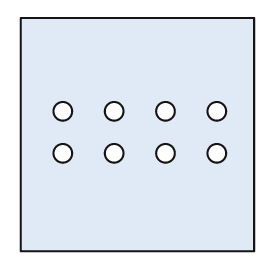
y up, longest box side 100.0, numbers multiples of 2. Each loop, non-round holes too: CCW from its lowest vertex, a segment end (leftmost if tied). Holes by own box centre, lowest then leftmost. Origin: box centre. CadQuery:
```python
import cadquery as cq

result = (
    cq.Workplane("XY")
    .moveTo(-50.0, -50.0)
    .lineTo(50.0, -50.0)
    .lineTo(50.0, 50.0)
    .lineTo(-50.0, 50.0)
    .close()
    .moveTo(-32.0, -8.0)
    .circle(4.0)
    .moveTo(-10.0, -8.0)
    .circle(4.0)
    .moveTo(12.0, -8.0)
    .circle(4.0)
    .moveTo(34.0, -8.0)
    .circle(4.0)
    .moveTo(-32.0, 10.0)
    .circle(4.0)
    .moveTo(-10.0, 10.0)
    .circle(4.0)
    .moveTo(12.0, 10.0)
    .circle(4.0)
    .moveTo(34.0, 10.0)
    .circle(4.0)
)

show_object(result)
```